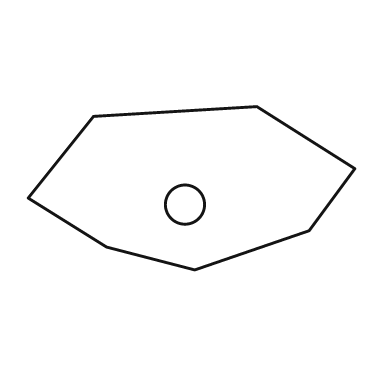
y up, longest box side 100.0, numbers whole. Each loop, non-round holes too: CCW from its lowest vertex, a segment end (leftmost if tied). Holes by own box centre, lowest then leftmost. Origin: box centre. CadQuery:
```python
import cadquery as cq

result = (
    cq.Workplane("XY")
    .moveTo(1.0, -25.0)
    .lineTo(36.0, -13.0)
    .lineTo(50.0, 6.0)
    .lineTo(20.0, 25.0)
    .lineTo(-30.0, 22.0)
    .lineTo(-50.0, -3.0)
    .lineTo(-26.0, -18.0)
    .close()
    .moveTo(-2.0, -5.0)
    .circle(6.0)
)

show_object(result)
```